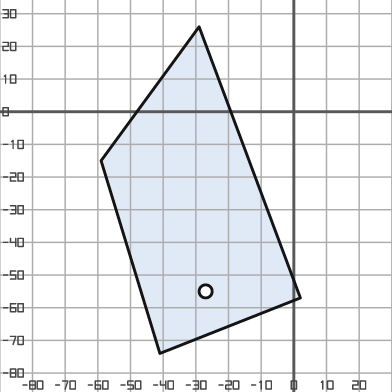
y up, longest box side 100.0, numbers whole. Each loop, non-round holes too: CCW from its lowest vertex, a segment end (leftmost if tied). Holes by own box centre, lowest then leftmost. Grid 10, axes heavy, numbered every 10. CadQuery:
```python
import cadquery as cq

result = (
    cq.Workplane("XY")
    .moveTo(-41.0, -74.0)
    .lineTo(2.0, -57.0)
    .lineTo(-29.0, 26.0)
    .lineTo(-59.0, -15.0)
    .close()
    .moveTo(-27.0, -55.0)
    .circle(2.0)
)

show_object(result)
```